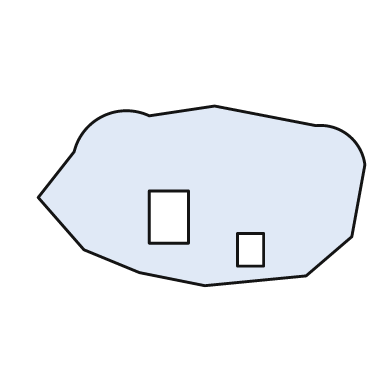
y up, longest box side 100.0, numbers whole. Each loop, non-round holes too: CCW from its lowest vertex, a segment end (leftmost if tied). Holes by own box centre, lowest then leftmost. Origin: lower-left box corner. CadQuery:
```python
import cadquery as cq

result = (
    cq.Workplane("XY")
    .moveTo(51.0, 0.0)
    .lineTo(82.0, 3.0)
    .lineTo(96.0, 15.0)
    .lineTo(100.0, 37.0)
    .threePointArc((95.0, 46.0), (85.0, 49.0))
    .lineTo(54.0, 55.0)
    .lineTo(34.0, 52.0)
    .threePointArc((20.0, 52.0), (11.0, 41.0))
    .lineTo(0.0, 27.0)
    .lineTo(14.0, 11.0)
    .lineTo(31.0, 4.0)
    .close()
    .moveTo(61.0, 6.0)
    .lineTo(69.0, 6.0)
    .lineTo(69.0, 16.0)
    .lineTo(61.0, 16.0)
    .close()
    .moveTo(34.0, 13.0)
    .lineTo(46.0, 13.0)
    .lineTo(46.0, 29.0)
    .lineTo(34.0, 29.0)
    .close()
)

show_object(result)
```